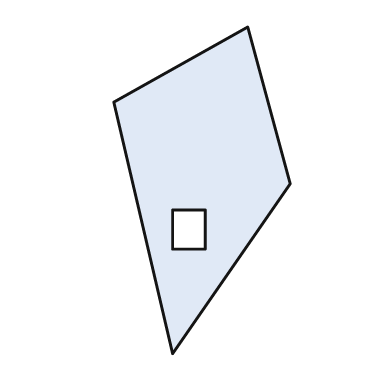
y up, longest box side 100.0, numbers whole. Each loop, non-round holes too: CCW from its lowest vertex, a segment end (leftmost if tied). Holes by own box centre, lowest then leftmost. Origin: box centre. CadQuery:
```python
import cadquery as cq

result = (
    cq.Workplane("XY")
    .moveTo(-9.0, -50.0)
    .lineTo(27.0, 2.0)
    .lineTo(14.0, 50.0)
    .lineTo(-27.0, 27.0)
    .close()
    .moveTo(-9.0, -18.0)
    .lineTo(1.0, -18.0)
    .lineTo(1.0, -6.0)
    .lineTo(-9.0, -6.0)
    .close()
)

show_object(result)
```